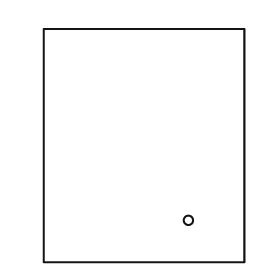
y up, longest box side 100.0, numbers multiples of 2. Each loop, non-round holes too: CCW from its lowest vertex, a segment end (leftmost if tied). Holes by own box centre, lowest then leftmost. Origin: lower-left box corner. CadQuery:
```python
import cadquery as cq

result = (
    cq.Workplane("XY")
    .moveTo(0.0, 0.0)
    .lineTo(86.0, 0.0)
    .lineTo(86.0, 100.0)
    .lineTo(0.0, 100.0)
    .close()
    .moveTo(62.0, 18.0)
    .circle(2.0)
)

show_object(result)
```